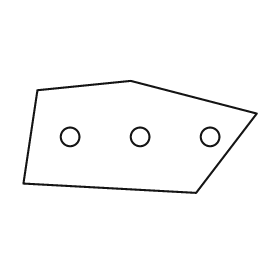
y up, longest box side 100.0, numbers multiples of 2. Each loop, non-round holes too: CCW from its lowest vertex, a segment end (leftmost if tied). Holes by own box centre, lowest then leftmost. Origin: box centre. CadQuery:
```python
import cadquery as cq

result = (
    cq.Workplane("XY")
    .moveTo(24.0, -24.0)
    .lineTo(50.0, 10.0)
    .lineTo(-4.0, 24.0)
    .lineTo(-44.0, 20.0)
    .lineTo(-50.0, -20.0)
    .close()
    .moveTo(-30.0, 0.0)
    .circle(4.0)
    .moveTo(0.0, 0.0)
    .circle(4.0)
    .moveTo(30.0, 0.0)
    .circle(4.0)
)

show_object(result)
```